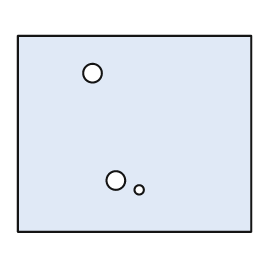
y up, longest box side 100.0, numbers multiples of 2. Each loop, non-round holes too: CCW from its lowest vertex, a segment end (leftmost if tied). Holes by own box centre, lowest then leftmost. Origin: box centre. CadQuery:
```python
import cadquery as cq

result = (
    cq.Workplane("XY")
    .moveTo(-50.0, -42.0)
    .lineTo(50.0, -42.0)
    .lineTo(50.0, 42.0)
    .lineTo(-50.0, 42.0)
    .close()
    .moveTo(2.0, -24.0)
    .circle(2.0)
    .moveTo(-8.0, -20.0)
    .circle(4.0)
    .moveTo(-18.0, 26.0)
    .circle(4.0)
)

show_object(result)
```